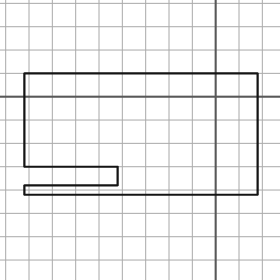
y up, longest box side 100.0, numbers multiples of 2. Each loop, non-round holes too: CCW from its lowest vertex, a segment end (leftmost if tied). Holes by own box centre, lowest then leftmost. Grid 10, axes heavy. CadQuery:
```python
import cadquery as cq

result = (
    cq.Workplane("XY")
    .moveTo(-82.0, -42.0)
    .lineTo(18.0, -42.0)
    .lineTo(18.0, 10.0)
    .lineTo(-82.0, 10.0)
    .lineTo(-82.0, -30.0)
    .lineTo(-42.0, -30.0)
    .lineTo(-42.0, -38.0)
    .lineTo(-82.0, -38.0)
    .close()
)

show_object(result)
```